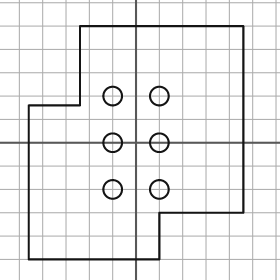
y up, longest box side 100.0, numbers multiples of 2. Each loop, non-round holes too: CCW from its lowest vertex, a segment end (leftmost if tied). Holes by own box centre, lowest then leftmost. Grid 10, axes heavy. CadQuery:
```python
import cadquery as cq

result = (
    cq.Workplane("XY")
    .moveTo(-46.0, -50.0)
    .lineTo(10.0, -50.0)
    .lineTo(10.0, -30.0)
    .lineTo(46.0, -30.0)
    .lineTo(46.0, 50.0)
    .lineTo(-24.0, 50.0)
    .lineTo(-24.0, 16.0)
    .lineTo(-46.0, 16.0)
    .close()
    .moveTo(-10.0, -20.0)
    .circle(4.0)
    .moveTo(10.0, -20.0)
    .circle(4.0)
    .moveTo(-10.0, 0.0)
    .circle(4.0)
    .moveTo(10.0, 0.0)
    .circle(4.0)
    .moveTo(-10.0, 20.0)
    .circle(4.0)
    .moveTo(10.0, 20.0)
    .circle(4.0)
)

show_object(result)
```